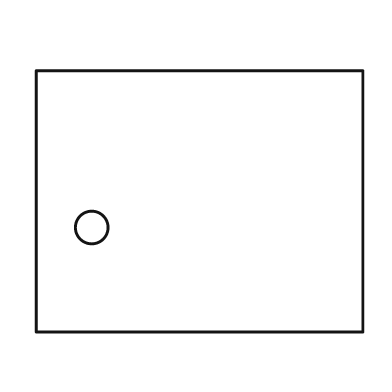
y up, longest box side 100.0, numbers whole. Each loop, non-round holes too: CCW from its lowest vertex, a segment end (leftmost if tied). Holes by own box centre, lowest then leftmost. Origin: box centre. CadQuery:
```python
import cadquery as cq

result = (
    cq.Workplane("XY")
    .moveTo(-50.0, -40.0)
    .lineTo(50.0, -40.0)
    .lineTo(50.0, 40.0)
    .lineTo(-50.0, 40.0)
    .close()
    .moveTo(-33.0, -8.0)
    .circle(5.0)
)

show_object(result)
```